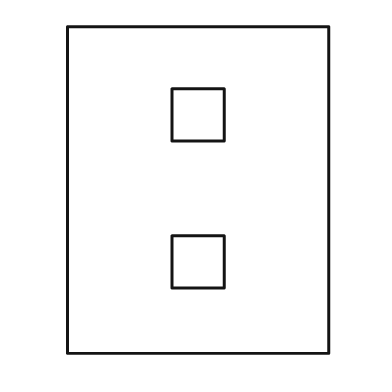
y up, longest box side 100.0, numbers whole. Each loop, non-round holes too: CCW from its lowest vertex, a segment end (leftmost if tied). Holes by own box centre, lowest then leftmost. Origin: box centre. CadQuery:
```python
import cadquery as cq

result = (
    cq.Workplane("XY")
    .moveTo(-40.0, -50.0)
    .lineTo(40.0, -50.0)
    .lineTo(40.0, 50.0)
    .lineTo(-40.0, 50.0)
    .close()
    .moveTo(-8.0, -30.0)
    .lineTo(8.0, -30.0)
    .lineTo(8.0, -14.0)
    .lineTo(-8.0, -14.0)
    .close()
    .moveTo(-8.0, 15.0)
    .lineTo(8.0, 15.0)
    .lineTo(8.0, 31.0)
    .lineTo(-8.0, 31.0)
    .close()
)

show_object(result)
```